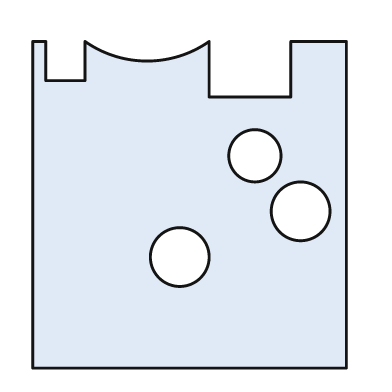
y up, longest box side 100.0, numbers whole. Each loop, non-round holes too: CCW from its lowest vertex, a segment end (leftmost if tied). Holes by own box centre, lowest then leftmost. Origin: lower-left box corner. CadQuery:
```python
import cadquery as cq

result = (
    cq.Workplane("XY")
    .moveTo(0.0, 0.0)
    .lineTo(96.0, 0.0)
    .lineTo(96.0, 100.0)
    .lineTo(79.0, 100.0)
    .lineTo(79.0, 83.0)
    .lineTo(54.0, 83.0)
    .lineTo(54.0, 100.0)
    .threePointArc((35.0, 94.0), (16.0, 100.0))
    .lineTo(16.0, 88.0)
    .lineTo(4.0, 88.0)
    .lineTo(4.0, 100.0)
    .lineTo(0.0, 100.0)
    .close()
    .moveTo(45.0, 34.0)
    .circle(9.0)
    .moveTo(82.0, 48.0)
    .circle(9.0)
    .moveTo(68.0, 65.0)
    .circle(8.0)
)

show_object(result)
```